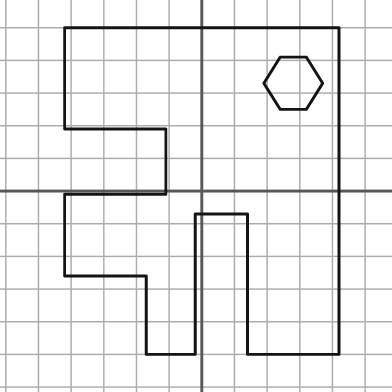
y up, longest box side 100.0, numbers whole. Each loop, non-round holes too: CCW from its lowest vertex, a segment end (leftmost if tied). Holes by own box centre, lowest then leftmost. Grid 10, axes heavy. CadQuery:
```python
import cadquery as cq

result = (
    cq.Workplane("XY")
    .moveTo(-17.0, -50.0)
    .lineTo(-2.0, -50.0)
    .lineTo(-2.0, -7.0)
    .lineTo(14.0, -7.0)
    .lineTo(14.0, -50.0)
    .lineTo(42.0, -50.0)
    .lineTo(42.0, 50.0)
    .lineTo(-42.0, 50.0)
    .lineTo(-42.0, 19.0)
    .lineTo(-11.0, 19.0)
    .lineTo(-11.0, -1.0)
    .lineTo(-42.0, -1.0)
    .lineTo(-42.0, -26.0)
    .lineTo(-17.0, -26.0)
    .close()
    .moveTo(24.0, 25.0)
    .lineTo(32.0, 25.0)
    .lineTo(37.0, 33.0)
    .lineTo(32.0, 41.0)
    .lineTo(24.0, 41.0)
    .lineTo(19.0, 33.0)
    .close()
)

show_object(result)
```